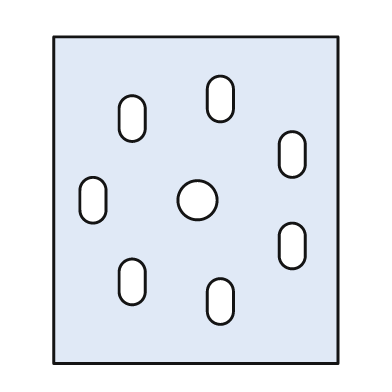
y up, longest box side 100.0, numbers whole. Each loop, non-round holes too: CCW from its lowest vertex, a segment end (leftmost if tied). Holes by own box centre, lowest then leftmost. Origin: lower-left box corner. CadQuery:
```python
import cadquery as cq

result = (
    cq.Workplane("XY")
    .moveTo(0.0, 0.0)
    .lineTo(87.0, 0.0)
    .lineTo(87.0, 100.0)
    .lineTo(0.0, 100.0)
    .close()
    .moveTo(47.0, 16.0)
    .threePointArc((51.0, 12.0), (55.0, 16.0))
    .lineTo(55.0, 22.0)
    .threePointArc((51.0, 26.0), (47.0, 22.0))
    .close()
    .moveTo(20.0, 22.0)
    .threePointArc((24.0, 18.0), (28.0, 22.0))
    .lineTo(28.0, 28.0)
    .threePointArc((24.0, 32.0), (20.0, 28.0))
    .close()
    .moveTo(69.0, 33.0)
    .threePointArc((73.0, 29.0), (77.0, 33.0))
    .lineTo(77.0, 39.0)
    .threePointArc((73.0, 43.0), (69.0, 39.0))
    .close()
    .moveTo(8.0, 47.0)
    .threePointArc((12.0, 43.0), (16.0, 47.0))
    .lineTo(16.0, 53.0)
    .threePointArc((12.0, 57.0), (8.0, 53.0))
    .close()
    .moveTo(44.0, 50.0)
    .circle(6.0)
    .moveTo(69.0, 61.0)
    .threePointArc((73.0, 57.0), (77.0, 61.0))
    .lineTo(77.0, 67.0)
    .threePointArc((73.0, 71.0), (69.0, 67.0))
    .close()
    .moveTo(20.0, 72.0)
    .threePointArc((24.0, 68.0), (28.0, 72.0))
    .lineTo(28.0, 78.0)
    .threePointArc((24.0, 82.0), (20.0, 78.0))
    .close()
    .moveTo(47.0, 78.0)
    .threePointArc((51.0, 74.0), (55.0, 78.0))
    .lineTo(55.0, 84.0)
    .threePointArc((51.0, 88.0), (47.0, 84.0))
    .close()
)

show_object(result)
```